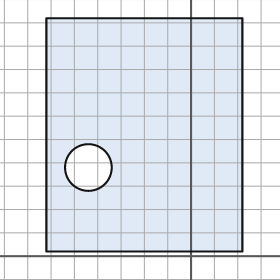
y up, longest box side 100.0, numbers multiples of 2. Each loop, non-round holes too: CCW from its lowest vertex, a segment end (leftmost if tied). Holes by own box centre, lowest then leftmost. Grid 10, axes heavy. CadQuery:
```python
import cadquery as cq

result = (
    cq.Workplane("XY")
    .moveTo(-62.0, 2.0)
    .lineTo(22.0, 2.0)
    .lineTo(22.0, 102.0)
    .lineTo(-62.0, 102.0)
    .close()
    .moveTo(-44.0, 38.0)
    .circle(10.0)
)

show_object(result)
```